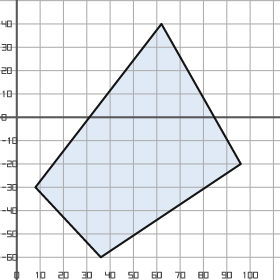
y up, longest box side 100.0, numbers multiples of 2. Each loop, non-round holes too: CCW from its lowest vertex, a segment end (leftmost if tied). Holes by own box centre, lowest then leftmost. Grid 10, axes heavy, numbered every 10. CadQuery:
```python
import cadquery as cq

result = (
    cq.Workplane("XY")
    .moveTo(36.0, -60.0)
    .lineTo(96.0, -20.0)
    .lineTo(62.0, 40.0)
    .lineTo(8.0, -30.0)
    .close()
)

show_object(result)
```